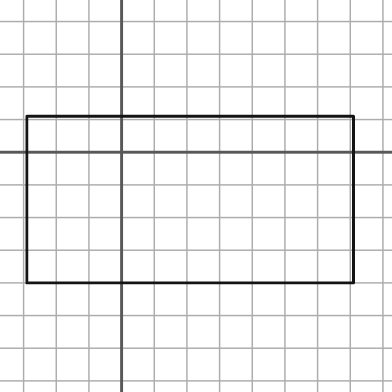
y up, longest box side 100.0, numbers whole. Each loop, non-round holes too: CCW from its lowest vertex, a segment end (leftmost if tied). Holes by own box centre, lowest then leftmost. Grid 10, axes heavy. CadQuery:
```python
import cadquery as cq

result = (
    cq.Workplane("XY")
    .moveTo(-29.0, -40.0)
    .lineTo(71.0, -40.0)
    .lineTo(71.0, 11.0)
    .lineTo(-29.0, 11.0)
    .close()
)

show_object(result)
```